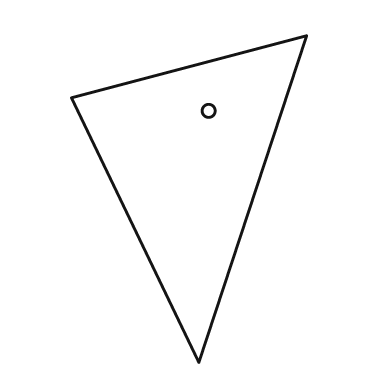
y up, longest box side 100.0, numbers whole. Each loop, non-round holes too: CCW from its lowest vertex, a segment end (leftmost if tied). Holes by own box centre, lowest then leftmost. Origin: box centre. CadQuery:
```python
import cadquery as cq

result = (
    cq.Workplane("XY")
    .moveTo(3.0, -50.0)
    .lineTo(36.0, 50.0)
    .lineTo(-36.0, 31.0)
    .close()
    .moveTo(6.0, 27.0)
    .circle(2.0)
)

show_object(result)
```